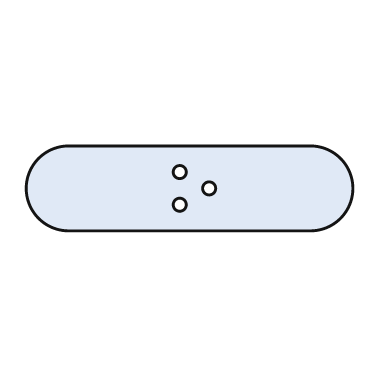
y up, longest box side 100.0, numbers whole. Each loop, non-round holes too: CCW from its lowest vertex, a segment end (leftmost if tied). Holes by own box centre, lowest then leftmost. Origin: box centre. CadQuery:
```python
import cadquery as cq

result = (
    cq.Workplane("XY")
    .moveTo(-37.0, -13.0)
    .lineTo(37.0, -13.0)
    .threePointArc((50.0, 0.0), (37.0, 13.0))
    .lineTo(-37.0, 13.0)
    .threePointArc((-50.0, 0.0), (-37.0, -13.0))
    .close()
    .moveTo(-3.0, -5.0)
    .circle(2.0)
    .moveTo(6.0, 0.0)
    .circle(2.0)
    .moveTo(-3.0, 5.0)
    .circle(2.0)
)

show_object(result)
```